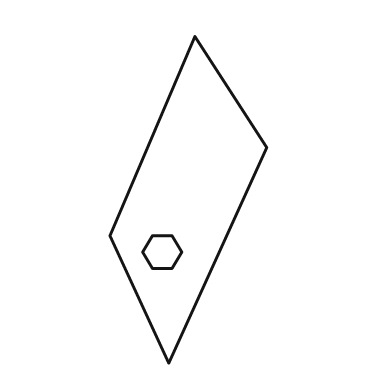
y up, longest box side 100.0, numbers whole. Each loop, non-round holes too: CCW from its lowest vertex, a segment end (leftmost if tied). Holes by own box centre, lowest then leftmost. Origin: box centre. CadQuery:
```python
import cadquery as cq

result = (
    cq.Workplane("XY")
    .moveTo(-6.0, -50.0)
    .lineTo(24.0, 16.0)
    .lineTo(2.0, 50.0)
    .lineTo(-24.0, -11.0)
    .close()
    .moveTo(-11.0, -21.0)
    .lineTo(-5.0, -21.0)
    .lineTo(-2.0, -16.0)
    .lineTo(-5.0, -11.0)
    .lineTo(-11.0, -11.0)
    .lineTo(-14.0, -16.0)
    .close()
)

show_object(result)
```